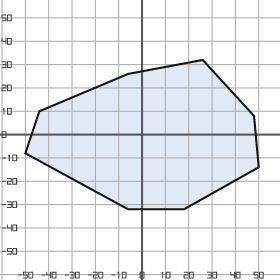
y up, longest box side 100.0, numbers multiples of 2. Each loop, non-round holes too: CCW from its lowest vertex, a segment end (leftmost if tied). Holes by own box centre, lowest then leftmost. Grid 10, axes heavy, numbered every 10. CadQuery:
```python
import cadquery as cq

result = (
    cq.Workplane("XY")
    .moveTo(-6.0, -32.0)
    .lineTo(18.0, -32.0)
    .lineTo(50.0, -14.0)
    .lineTo(48.0, 8.0)
    .lineTo(26.0, 32.0)
    .lineTo(-6.0, 26.0)
    .lineTo(-44.0, 10.0)
    .lineTo(-50.0, -8.0)
    .close()
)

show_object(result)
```